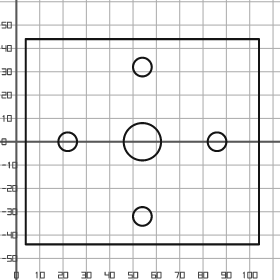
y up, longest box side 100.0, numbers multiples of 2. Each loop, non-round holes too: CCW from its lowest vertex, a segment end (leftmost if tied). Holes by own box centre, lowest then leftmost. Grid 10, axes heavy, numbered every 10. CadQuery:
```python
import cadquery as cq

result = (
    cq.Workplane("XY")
    .moveTo(4.0, -44.0)
    .lineTo(104.0, -44.0)
    .lineTo(104.0, 44.0)
    .lineTo(4.0, 44.0)
    .close()
    .moveTo(54.0, -32.0)
    .circle(4.0)
    .moveTo(22.0, 0.0)
    .circle(4.0)
    .moveTo(54.0, 0.0)
    .circle(8.0)
    .moveTo(86.0, 0.0)
    .circle(4.0)
    .moveTo(54.0, 32.0)
    .circle(4.0)
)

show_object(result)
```